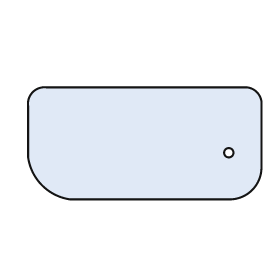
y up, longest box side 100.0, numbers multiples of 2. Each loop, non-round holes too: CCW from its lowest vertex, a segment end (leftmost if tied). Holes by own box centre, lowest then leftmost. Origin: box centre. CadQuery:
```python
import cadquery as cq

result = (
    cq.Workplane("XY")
    .moveTo(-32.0, -24.0)
    .lineTo(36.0, -24.0)
    .threePointArc((46.0, -20.0), (50.0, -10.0))
    .lineTo(50.0, 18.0)
    .threePointArc((48.0, 22.0), (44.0, 24.0))
    .lineTo(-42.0, 24.0)
    .threePointArc((-48.0, 22.0), (-50.0, 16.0))
    .lineTo(-50.0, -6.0)
    .threePointArc((-44.0, -18.0), (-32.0, -24.0))
    .close()
    .moveTo(36.0, -4.0)
    .circle(2.0)
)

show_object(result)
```